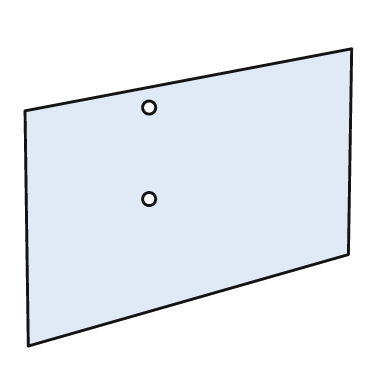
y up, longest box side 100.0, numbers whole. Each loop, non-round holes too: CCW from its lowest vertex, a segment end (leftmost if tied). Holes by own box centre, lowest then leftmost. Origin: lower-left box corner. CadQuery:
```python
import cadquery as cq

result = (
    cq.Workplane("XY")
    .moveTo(1.0, 0.0)
    .lineTo(99.0, 28.0)
    .lineTo(100.0, 91.0)
    .lineTo(0.0, 72.0)
    .close()
    .moveTo(38.0, 45.0)
    .circle(2.0)
    .moveTo(38.0, 73.0)
    .circle(2.0)
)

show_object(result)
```